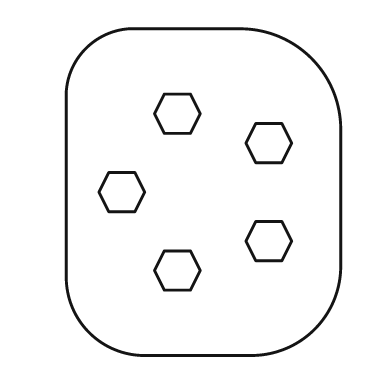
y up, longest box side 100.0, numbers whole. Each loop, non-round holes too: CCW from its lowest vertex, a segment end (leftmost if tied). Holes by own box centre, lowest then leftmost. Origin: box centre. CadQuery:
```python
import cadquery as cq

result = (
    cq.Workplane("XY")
    .moveTo(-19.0, -50.0)
    .lineTo(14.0, -50.0)
    .threePointArc((34.0, -42.0), (42.0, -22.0))
    .lineTo(42.0, 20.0)
    .threePointArc((33.0, 41.0), (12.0, 50.0))
    .lineTo(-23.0, 50.0)
    .threePointArc((-36.0, 44.0), (-42.0, 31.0))
    .lineTo(-42.0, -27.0)
    .threePointArc((-35.0, -43.0), (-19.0, -50.0))
    .close()
    .moveTo(-12.0, -30.0)
    .lineTo(-4.0, -30.0)
    .lineTo(-1.0, -24.0)
    .lineTo(-4.0, -18.0)
    .lineTo(-12.0, -18.0)
    .lineTo(-15.0, -24.0)
    .close()
    .moveTo(16.0, -21.0)
    .lineTo(24.0, -21.0)
    .lineTo(27.0, -15.0)
    .lineTo(24.0, -9.0)
    .lineTo(16.0, -9.0)
    .lineTo(13.0, -15.0)
    .close()
    .moveTo(-29.0, -6.0)
    .lineTo(-21.0, -6.0)
    .lineTo(-18.0, 0.0)
    .lineTo(-21.0, 6.0)
    .lineTo(-29.0, 6.0)
    .lineTo(-32.0, 0.0)
    .close()
    .moveTo(16.0, 9.0)
    .lineTo(24.0, 9.0)
    .lineTo(27.0, 15.0)
    .lineTo(24.0, 21.0)
    .lineTo(16.0, 21.0)
    .lineTo(13.0, 15.0)
    .close()
    .moveTo(-12.0, 18.0)
    .lineTo(-4.0, 18.0)
    .lineTo(-1.0, 24.0)
    .lineTo(-4.0, 30.0)
    .lineTo(-12.0, 30.0)
    .lineTo(-15.0, 24.0)
    .close()
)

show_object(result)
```